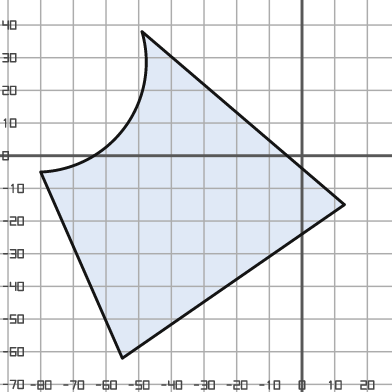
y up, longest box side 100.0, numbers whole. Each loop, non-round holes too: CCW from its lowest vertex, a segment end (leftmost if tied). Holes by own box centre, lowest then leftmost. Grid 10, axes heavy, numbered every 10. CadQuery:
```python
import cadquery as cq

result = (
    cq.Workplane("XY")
    .moveTo(-55.0, -62.0)
    .lineTo(13.0, -15.0)
    .lineTo(-49.0, 38.0)
    .threePointArc((-54.0, 9.0), (-80.0, -5.0))
    .close()
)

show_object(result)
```